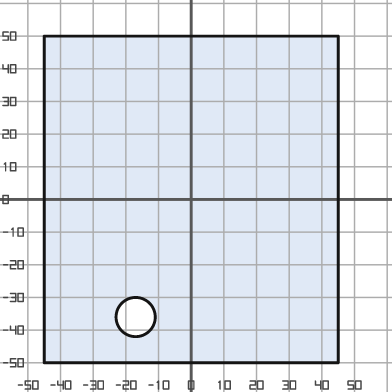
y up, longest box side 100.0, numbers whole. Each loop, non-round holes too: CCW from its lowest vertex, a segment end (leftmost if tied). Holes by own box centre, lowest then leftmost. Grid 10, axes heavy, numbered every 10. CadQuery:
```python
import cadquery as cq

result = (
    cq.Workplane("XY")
    .moveTo(-45.0, -50.0)
    .lineTo(45.0, -50.0)
    .lineTo(45.0, 50.0)
    .lineTo(-45.0, 50.0)
    .close()
    .moveTo(-17.0, -36.0)
    .circle(6.0)
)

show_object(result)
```